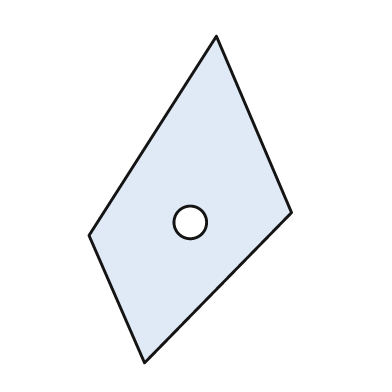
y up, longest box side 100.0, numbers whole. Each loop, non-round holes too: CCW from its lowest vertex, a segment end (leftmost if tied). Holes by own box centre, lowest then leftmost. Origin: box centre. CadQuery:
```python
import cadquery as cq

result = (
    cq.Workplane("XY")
    .moveTo(-14.0, -50.0)
    .lineTo(31.0, -4.0)
    .lineTo(8.0, 50.0)
    .lineTo(-31.0, -11.0)
    .close()
    .moveTo(0.0, -7.0)
    .circle(5.0)
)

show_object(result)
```